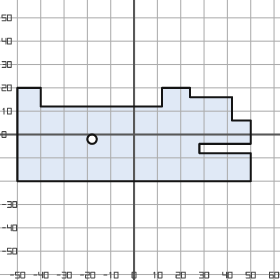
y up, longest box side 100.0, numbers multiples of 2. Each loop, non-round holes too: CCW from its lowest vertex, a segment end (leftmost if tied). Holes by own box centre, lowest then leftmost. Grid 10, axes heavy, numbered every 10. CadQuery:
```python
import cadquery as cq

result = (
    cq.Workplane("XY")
    .moveTo(-50.0, -20.0)
    .lineTo(50.0, -20.0)
    .lineTo(50.0, -8.0)
    .lineTo(28.0, -8.0)
    .lineTo(28.0, -4.0)
    .lineTo(50.0, -4.0)
    .lineTo(50.0, 6.0)
    .lineTo(42.0, 6.0)
    .lineTo(42.0, 16.0)
    .lineTo(24.0, 16.0)
    .lineTo(24.0, 20.0)
    .lineTo(12.0, 20.0)
    .lineTo(12.0, 12.0)
    .lineTo(-40.0, 12.0)
    .lineTo(-40.0, 20.0)
    .lineTo(-50.0, 20.0)
    .close()
    .moveTo(-18.0, -2.0)
    .circle(2.0)
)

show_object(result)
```